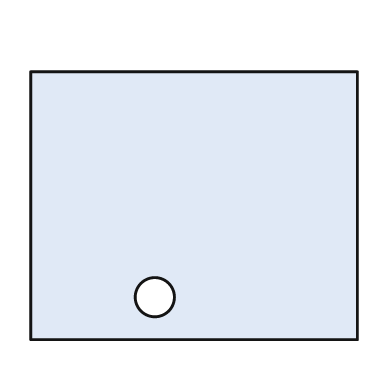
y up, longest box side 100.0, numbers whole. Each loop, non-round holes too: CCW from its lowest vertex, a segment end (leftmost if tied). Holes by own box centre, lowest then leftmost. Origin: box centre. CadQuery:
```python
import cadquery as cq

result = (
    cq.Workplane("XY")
    .moveTo(-50.0, -41.0)
    .lineTo(50.0, -41.0)
    .lineTo(50.0, 41.0)
    .lineTo(-50.0, 41.0)
    .close()
    .moveTo(-12.0, -28.0)
    .circle(6.0)
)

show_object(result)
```